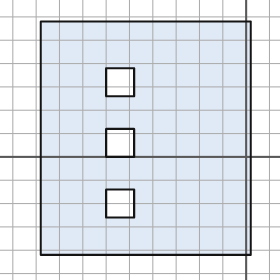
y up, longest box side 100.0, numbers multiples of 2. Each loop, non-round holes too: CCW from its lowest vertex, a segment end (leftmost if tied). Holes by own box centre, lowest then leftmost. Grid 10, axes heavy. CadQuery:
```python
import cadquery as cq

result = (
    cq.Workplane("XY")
    .moveTo(-88.0, -42.0)
    .lineTo(2.0, -42.0)
    .lineTo(2.0, 58.0)
    .lineTo(-88.0, 58.0)
    .close()
    .moveTo(-60.0, -26.0)
    .lineTo(-48.0, -26.0)
    .lineTo(-48.0, -14.0)
    .lineTo(-60.0, -14.0)
    .close()
    .moveTo(-60.0, 0.0)
    .lineTo(-48.0, 0.0)
    .lineTo(-48.0, 12.0)
    .lineTo(-60.0, 12.0)
    .close()
    .moveTo(-60.0, 26.0)
    .lineTo(-48.0, 26.0)
    .lineTo(-48.0, 38.0)
    .lineTo(-60.0, 38.0)
    .close()
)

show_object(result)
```